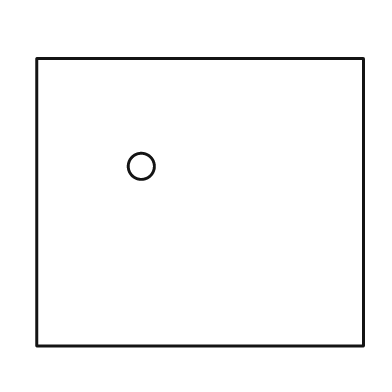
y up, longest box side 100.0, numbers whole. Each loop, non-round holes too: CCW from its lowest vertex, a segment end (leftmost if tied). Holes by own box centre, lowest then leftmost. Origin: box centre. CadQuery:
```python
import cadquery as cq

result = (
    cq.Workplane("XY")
    .moveTo(-50.0, -44.0)
    .lineTo(50.0, -44.0)
    .lineTo(50.0, 44.0)
    .lineTo(-50.0, 44.0)
    .close()
    .moveTo(-18.0, 11.0)
    .circle(4.0)
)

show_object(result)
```